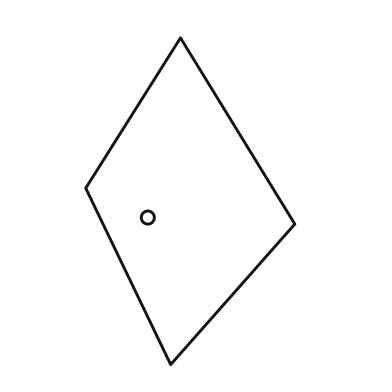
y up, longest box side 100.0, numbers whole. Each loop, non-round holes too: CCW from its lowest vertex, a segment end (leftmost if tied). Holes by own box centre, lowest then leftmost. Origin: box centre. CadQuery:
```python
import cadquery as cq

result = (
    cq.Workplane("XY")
    .moveTo(-6.0, -50.0)
    .lineTo(32.0, -7.0)
    .lineTo(-3.0, 50.0)
    .lineTo(-32.0, 4.0)
    .close()
    .moveTo(-13.0, -5.0)
    .circle(2.0)
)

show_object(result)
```